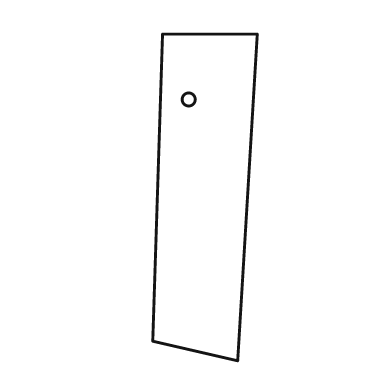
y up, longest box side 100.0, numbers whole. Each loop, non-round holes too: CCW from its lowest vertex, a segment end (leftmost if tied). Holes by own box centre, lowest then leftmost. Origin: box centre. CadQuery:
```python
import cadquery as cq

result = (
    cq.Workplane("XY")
    .moveTo(10.0, -50.0)
    .lineTo(16.0, 50.0)
    .lineTo(-13.0, 50.0)
    .lineTo(-16.0, -44.0)
    .close()
    .moveTo(-5.0, 30.0)
    .circle(2.0)
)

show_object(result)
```